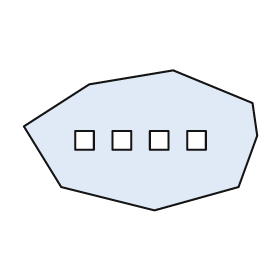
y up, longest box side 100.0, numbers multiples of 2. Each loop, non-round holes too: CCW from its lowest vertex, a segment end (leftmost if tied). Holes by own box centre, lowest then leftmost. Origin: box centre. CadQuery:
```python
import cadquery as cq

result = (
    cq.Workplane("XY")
    .moveTo(6.0, -30.0)
    .lineTo(42.0, -20.0)
    .lineTo(50.0, 2.0)
    .lineTo(48.0, 16.0)
    .lineTo(14.0, 30.0)
    .lineTo(-22.0, 24.0)
    .lineTo(-50.0, 6.0)
    .lineTo(-34.0, -20.0)
    .close()
    .moveTo(-28.0, -4.0)
    .lineTo(-20.0, -4.0)
    .lineTo(-20.0, 4.0)
    .lineTo(-28.0, 4.0)
    .close()
    .moveTo(-12.0, -4.0)
    .lineTo(-4.0, -4.0)
    .lineTo(-4.0, 4.0)
    .lineTo(-12.0, 4.0)
    .close()
    .moveTo(4.0, -4.0)
    .lineTo(12.0, -4.0)
    .lineTo(12.0, 4.0)
    .lineTo(4.0, 4.0)
    .close()
    .moveTo(20.0, -4.0)
    .lineTo(28.0, -4.0)
    .lineTo(28.0, 4.0)
    .lineTo(20.0, 4.0)
    .close()
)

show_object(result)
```